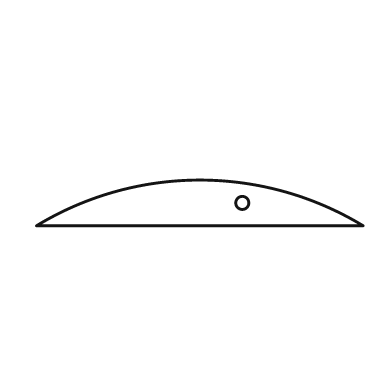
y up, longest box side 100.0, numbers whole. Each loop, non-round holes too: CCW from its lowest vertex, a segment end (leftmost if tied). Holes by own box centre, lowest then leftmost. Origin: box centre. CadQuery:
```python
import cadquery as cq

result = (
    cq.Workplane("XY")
    .moveTo(-50.0, -7.0)
    .lineTo(50.0, -7.0)
    .threePointArc((0.0, 7.0), (-50.0, -7.0))
    .close()
    .moveTo(13.0, 0.0)
    .circle(2.0)
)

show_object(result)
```